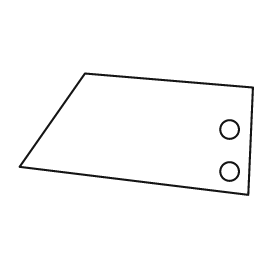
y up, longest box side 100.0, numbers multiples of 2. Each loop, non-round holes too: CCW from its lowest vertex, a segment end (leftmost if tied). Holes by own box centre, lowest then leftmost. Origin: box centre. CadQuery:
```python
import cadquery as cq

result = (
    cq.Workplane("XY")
    .moveTo(48.0, -26.0)
    .lineTo(50.0, 20.0)
    .lineTo(-22.0, 26.0)
    .lineTo(-50.0, -14.0)
    .close()
    .moveTo(40.0, -16.0)
    .circle(4.0)
    .moveTo(40.0, 2.0)
    .circle(4.0)
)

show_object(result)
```